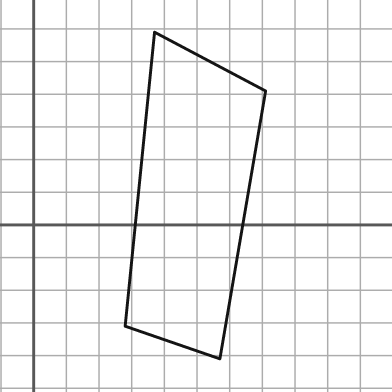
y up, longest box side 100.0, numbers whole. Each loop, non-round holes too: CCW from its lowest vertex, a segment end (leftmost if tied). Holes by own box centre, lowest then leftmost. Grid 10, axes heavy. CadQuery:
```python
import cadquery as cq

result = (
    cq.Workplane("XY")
    .moveTo(57.0, -41.0)
    .lineTo(71.0, 41.0)
    .lineTo(37.0, 59.0)
    .lineTo(28.0, -31.0)
    .close()
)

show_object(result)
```